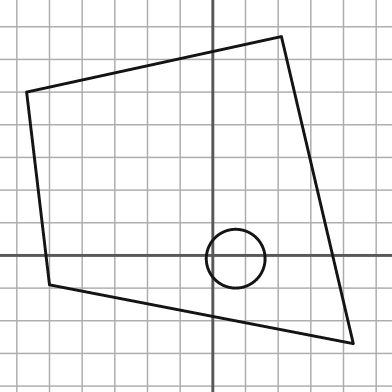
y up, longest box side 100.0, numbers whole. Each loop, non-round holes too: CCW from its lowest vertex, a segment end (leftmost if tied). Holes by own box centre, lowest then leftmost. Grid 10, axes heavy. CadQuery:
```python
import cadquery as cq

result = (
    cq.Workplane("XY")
    .moveTo(43.0, -27.0)
    .lineTo(21.0, 67.0)
    .lineTo(-57.0, 50.0)
    .lineTo(-50.0, -9.0)
    .close()
    .moveTo(7.0, -1.0)
    .circle(9.0)
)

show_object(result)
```